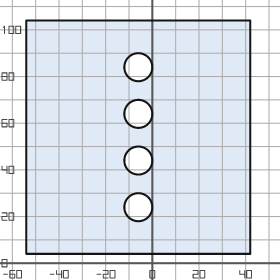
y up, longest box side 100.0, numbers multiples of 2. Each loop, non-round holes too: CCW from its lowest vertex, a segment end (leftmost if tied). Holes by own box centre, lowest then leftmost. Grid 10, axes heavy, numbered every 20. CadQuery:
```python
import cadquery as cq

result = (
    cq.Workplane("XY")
    .moveTo(-54.0, 4.0)
    .lineTo(42.0, 4.0)
    .lineTo(42.0, 104.0)
    .lineTo(-54.0, 104.0)
    .close()
    .moveTo(-6.0, 24.0)
    .circle(6.0)
    .moveTo(-6.0, 44.0)
    .circle(6.0)
    .moveTo(-6.0, 64.0)
    .circle(6.0)
    .moveTo(-6.0, 84.0)
    .circle(6.0)
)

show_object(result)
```